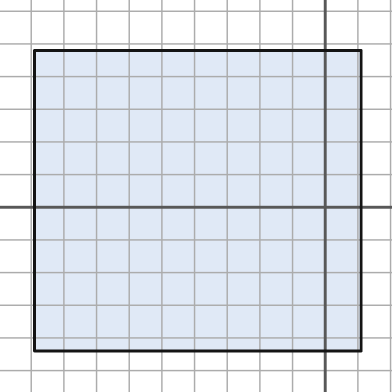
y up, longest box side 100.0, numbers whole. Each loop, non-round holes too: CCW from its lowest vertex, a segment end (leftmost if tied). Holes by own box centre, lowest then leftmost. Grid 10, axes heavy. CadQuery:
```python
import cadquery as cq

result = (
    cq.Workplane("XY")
    .moveTo(-89.0, -44.0)
    .lineTo(11.0, -44.0)
    .lineTo(11.0, 48.0)
    .lineTo(-89.0, 48.0)
    .close()
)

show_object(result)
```